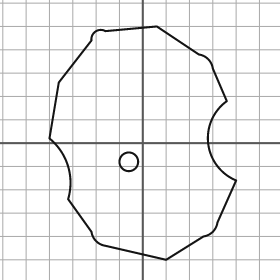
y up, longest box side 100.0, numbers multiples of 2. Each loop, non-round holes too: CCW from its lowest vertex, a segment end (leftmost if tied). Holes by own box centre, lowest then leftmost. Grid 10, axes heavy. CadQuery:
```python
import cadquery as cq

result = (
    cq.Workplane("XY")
    .moveTo(10.0, -50.0)
    .lineTo(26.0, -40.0)
    .threePointArc((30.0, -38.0), (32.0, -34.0))
    .lineTo(40.0, -16.0)
    .threePointArc((28.0, 0.0), (36.0, 18.0))
    .lineTo(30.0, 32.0)
    .threePointArc((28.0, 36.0), (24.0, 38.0))
    .lineTo(6.0, 50.0)
    .lineTo(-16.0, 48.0)
    .threePointArc((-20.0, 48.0), (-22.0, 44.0))
    .lineTo(-36.0, 26.0)
    .lineTo(-40.0, 2.0)
    .threePointArc((-32.0, -10.0), (-32.0, -24.0))
    .lineTo(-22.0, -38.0)
    .threePointArc((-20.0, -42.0), (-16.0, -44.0))
    .close()
    .moveTo(-6.0, -8.0)
    .circle(4.0)
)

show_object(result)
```